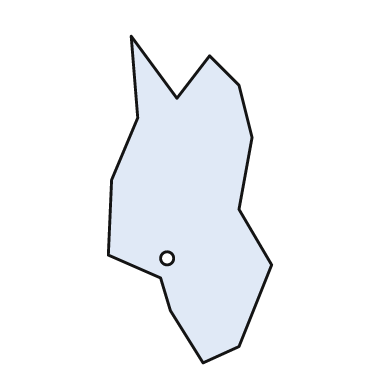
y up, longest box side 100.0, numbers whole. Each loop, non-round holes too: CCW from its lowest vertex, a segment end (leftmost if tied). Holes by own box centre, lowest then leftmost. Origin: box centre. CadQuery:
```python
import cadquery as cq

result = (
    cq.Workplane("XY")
    .moveTo(4.0, -50.0)
    .lineTo(15.0, -45.0)
    .lineTo(25.0, -20.0)
    .lineTo(15.0, -3.0)
    .lineTo(19.0, 19.0)
    .lineTo(15.0, 35.0)
    .lineTo(6.0, 44.0)
    .lineTo(-4.0, 31.0)
    .lineTo(-18.0, 50.0)
    .lineTo(-16.0, 25.0)
    .lineTo(-24.0, 6.0)
    .lineTo(-25.0, -17.0)
    .lineTo(-9.0, -24.0)
    .lineTo(-6.0, -34.0)
    .close()
    .moveTo(-7.0, -18.0)
    .circle(2.0)
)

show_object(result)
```